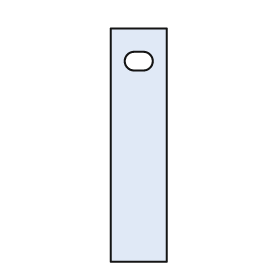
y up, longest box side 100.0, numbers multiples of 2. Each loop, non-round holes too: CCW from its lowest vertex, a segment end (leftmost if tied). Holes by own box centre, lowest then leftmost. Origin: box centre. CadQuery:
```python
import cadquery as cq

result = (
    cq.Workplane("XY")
    .moveTo(-12.0, -50.0)
    .lineTo(12.0, -50.0)
    .lineTo(12.0, 50.0)
    .lineTo(-12.0, 50.0)
    .close()
    .moveTo(-2.0, 32.0)
    .lineTo(2.0, 32.0)
    .threePointArc((6.0, 36.0), (2.0, 40.0))
    .lineTo(-2.0, 40.0)
    .threePointArc((-6.0, 36.0), (-2.0, 32.0))
    .close()
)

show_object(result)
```